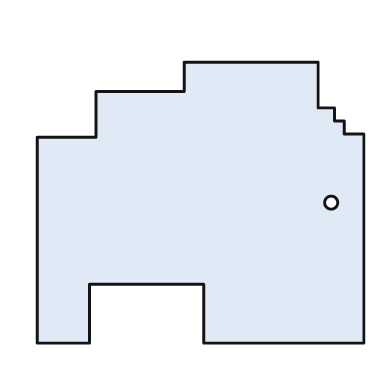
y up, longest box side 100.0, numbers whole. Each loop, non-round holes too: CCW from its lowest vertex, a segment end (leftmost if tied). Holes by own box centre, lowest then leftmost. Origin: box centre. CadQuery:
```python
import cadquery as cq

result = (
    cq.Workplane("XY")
    .moveTo(-50.0, -43.0)
    .lineTo(-34.0, -43.0)
    .lineTo(-34.0, -25.0)
    .lineTo(1.0, -25.0)
    .lineTo(1.0, -43.0)
    .lineTo(50.0, -43.0)
    .lineTo(50.0, 21.0)
    .lineTo(44.0, 21.0)
    .lineTo(44.0, 25.0)
    .lineTo(41.0, 25.0)
    .lineTo(41.0, 29.0)
    .lineTo(36.0, 29.0)
    .lineTo(36.0, 43.0)
    .lineTo(-5.0, 43.0)
    .lineTo(-5.0, 34.0)
    .lineTo(-32.0, 34.0)
    .lineTo(-32.0, 20.0)
    .lineTo(-50.0, 20.0)
    .close()
    .moveTo(40.0, 0.0)
    .circle(2.0)
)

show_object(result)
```